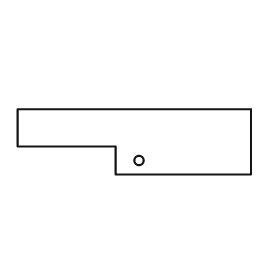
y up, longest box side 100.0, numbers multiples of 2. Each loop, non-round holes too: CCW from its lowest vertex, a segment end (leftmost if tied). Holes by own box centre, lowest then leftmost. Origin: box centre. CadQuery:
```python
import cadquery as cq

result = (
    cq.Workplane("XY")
    .moveTo(-8.0, -14.0)
    .lineTo(50.0, -14.0)
    .lineTo(50.0, 14.0)
    .lineTo(-50.0, 14.0)
    .lineTo(-50.0, -2.0)
    .lineTo(-8.0, -2.0)
    .close()
    .moveTo(2.0, -8.0)
    .circle(2.0)
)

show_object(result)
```